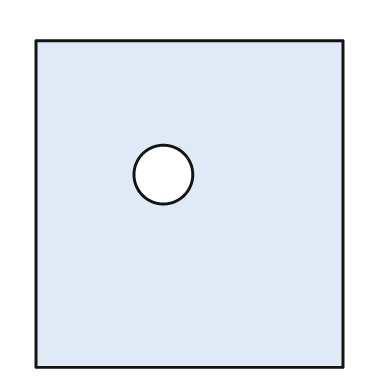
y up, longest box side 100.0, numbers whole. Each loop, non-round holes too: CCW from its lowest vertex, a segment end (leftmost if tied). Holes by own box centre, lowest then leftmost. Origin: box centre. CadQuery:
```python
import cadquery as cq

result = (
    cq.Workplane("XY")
    .moveTo(-47.0, -50.0)
    .lineTo(47.0, -50.0)
    .lineTo(47.0, 50.0)
    .lineTo(-47.0, 50.0)
    .close()
    .moveTo(-8.0, 9.0)
    .circle(9.0)
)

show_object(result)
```